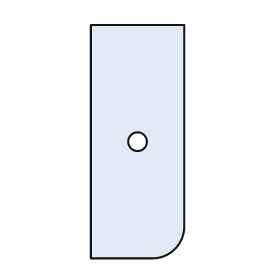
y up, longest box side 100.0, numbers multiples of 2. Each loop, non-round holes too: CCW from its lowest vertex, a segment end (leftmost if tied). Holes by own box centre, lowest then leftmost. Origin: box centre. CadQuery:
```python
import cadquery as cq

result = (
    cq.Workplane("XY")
    .moveTo(-20.0, -50.0)
    .lineTo(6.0, -50.0)
    .threePointArc((16.0, -46.0), (20.0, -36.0))
    .lineTo(20.0, 50.0)
    .lineTo(-20.0, 50.0)
    .close()
    .moveTo(0.0, 0.0)
    .circle(4.0)
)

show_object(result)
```